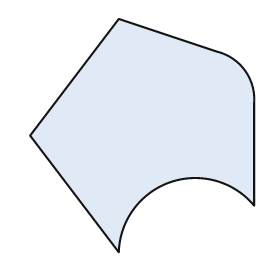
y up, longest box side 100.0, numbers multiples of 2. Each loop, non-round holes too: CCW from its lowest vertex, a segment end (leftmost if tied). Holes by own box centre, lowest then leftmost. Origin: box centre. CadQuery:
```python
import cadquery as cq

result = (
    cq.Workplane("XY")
    .moveTo(-10.0, -50.0)
    .threePointArc((12.0, -20.0), (48.0, -30.0))
    .lineTo(48.0, 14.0)
    .threePointArc((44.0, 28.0), (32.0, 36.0))
    .lineTo(-10.0, 50.0)
    .lineTo(-48.0, 0.0)
    .close()
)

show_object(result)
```